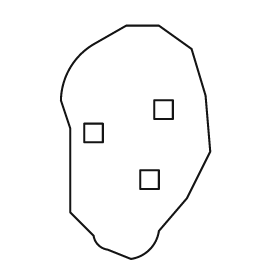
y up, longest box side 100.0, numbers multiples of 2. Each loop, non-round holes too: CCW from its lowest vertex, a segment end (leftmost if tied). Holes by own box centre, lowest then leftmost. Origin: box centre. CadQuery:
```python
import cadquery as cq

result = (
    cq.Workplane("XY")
    .moveTo(-2.0, -50.0)
    .threePointArc((6.0, -46.0), (10.0, -38.0))
    .lineTo(22.0, -24.0)
    .lineTo(32.0, -4.0)
    .lineTo(30.0, 20.0)
    .lineTo(24.0, 40.0)
    .lineTo(10.0, 50.0)
    .lineTo(-4.0, 50.0)
    .lineTo(-18.0, 42.0)
    .threePointArc((-28.0, 32.0), (-32.0, 18.0))
    .lineTo(-28.0, 6.0)
    .lineTo(-28.0, -30.0)
    .lineTo(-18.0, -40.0)
    .threePointArc((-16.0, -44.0), (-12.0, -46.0))
    .close()
    .moveTo(2.0, -20.0)
    .lineTo(10.0, -20.0)
    .lineTo(10.0, -12.0)
    .lineTo(2.0, -12.0)
    .close()
    .moveTo(-22.0, 0.0)
    .lineTo(-14.0, 0.0)
    .lineTo(-14.0, 8.0)
    .lineTo(-22.0, 8.0)
    .close()
    .moveTo(8.0, 10.0)
    .lineTo(16.0, 10.0)
    .lineTo(16.0, 18.0)
    .lineTo(8.0, 18.0)
    .close()
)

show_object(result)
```